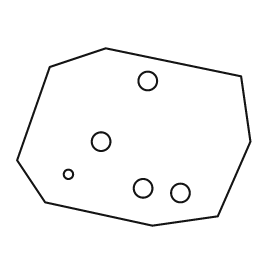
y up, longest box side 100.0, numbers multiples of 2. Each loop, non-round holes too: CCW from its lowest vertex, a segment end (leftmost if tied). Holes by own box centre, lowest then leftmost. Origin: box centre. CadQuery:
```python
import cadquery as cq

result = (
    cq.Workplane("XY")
    .moveTo(8.0, -38.0)
    .lineTo(36.0, -34.0)
    .lineTo(50.0, -2.0)
    .lineTo(46.0, 26.0)
    .lineTo(-12.0, 38.0)
    .lineTo(-36.0, 30.0)
    .lineTo(-50.0, -10.0)
    .lineTo(-38.0, -28.0)
    .close()
    .moveTo(20.0, -24.0)
    .circle(4.0)
    .moveTo(4.0, -22.0)
    .circle(4.0)
    .moveTo(-28.0, -16.0)
    .circle(2.0)
    .moveTo(-14.0, -2.0)
    .circle(4.0)
    .moveTo(6.0, 24.0)
    .circle(4.0)
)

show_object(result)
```